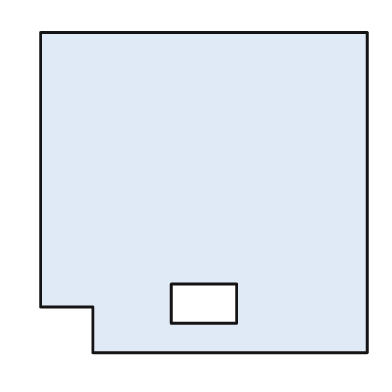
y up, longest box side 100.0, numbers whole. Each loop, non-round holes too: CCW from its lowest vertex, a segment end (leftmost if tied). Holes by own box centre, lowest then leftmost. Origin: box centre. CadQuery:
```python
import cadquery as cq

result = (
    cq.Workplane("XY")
    .moveTo(-34.0, -49.0)
    .lineTo(50.0, -49.0)
    .lineTo(50.0, 49.0)
    .lineTo(-50.0, 49.0)
    .lineTo(-50.0, -35.0)
    .lineTo(-34.0, -35.0)
    .close()
    .moveTo(-10.0, -40.0)
    .lineTo(10.0, -40.0)
    .lineTo(10.0, -28.0)
    .lineTo(-10.0, -28.0)
    .close()
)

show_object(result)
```